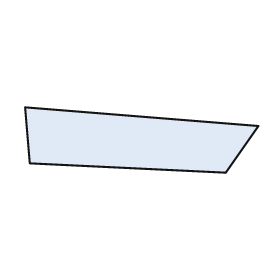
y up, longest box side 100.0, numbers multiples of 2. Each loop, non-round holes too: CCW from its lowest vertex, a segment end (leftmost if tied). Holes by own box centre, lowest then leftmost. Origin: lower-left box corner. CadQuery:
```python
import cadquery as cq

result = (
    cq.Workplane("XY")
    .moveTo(86.0, 0.0)
    .lineTo(100.0, 20.0)
    .lineTo(0.0, 28.0)
    .lineTo(2.0, 4.0)
    .close()
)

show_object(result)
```